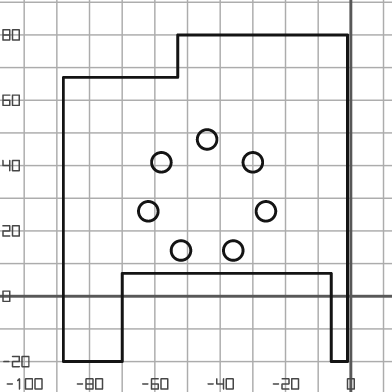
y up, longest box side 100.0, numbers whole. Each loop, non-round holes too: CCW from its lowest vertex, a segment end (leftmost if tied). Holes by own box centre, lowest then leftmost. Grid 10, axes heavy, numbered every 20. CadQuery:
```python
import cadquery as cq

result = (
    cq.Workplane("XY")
    .moveTo(-88.0, -20.0)
    .lineTo(-70.0, -20.0)
    .lineTo(-70.0, 7.0)
    .lineTo(-6.0, 7.0)
    .lineTo(-6.0, -20.0)
    .lineTo(-1.0, -20.0)
    .lineTo(-1.0, 80.0)
    .lineTo(-53.0, 80.0)
    .lineTo(-53.0, 67.0)
    .lineTo(-88.0, 67.0)
    .close()
    .moveTo(-52.0, 14.0)
    .circle(3.0)
    .moveTo(-36.0, 14.0)
    .circle(3.0)
    .moveTo(-62.0, 26.0)
    .circle(3.0)
    .moveTo(-26.0, 26.0)
    .circle(3.0)
    .moveTo(-58.0, 41.0)
    .circle(3.0)
    .moveTo(-30.0, 41.0)
    .circle(3.0)
    .moveTo(-44.0, 48.0)
    .circle(3.0)
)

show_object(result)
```